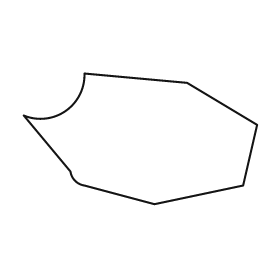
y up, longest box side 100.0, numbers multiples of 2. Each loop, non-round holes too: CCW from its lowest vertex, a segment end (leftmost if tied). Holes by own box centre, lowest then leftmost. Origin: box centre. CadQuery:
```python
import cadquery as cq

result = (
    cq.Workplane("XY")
    .moveTo(6.0, -28.0)
    .lineTo(44.0, -20.0)
    .lineTo(50.0, 6.0)
    .lineTo(20.0, 24.0)
    .lineTo(-24.0, 28.0)
    .threePointArc((-32.0, 12.0), (-50.0, 10.0))
    .lineTo(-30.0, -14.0)
    .threePointArc((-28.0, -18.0), (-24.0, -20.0))
    .close()
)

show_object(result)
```